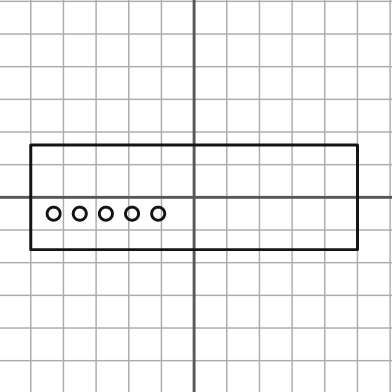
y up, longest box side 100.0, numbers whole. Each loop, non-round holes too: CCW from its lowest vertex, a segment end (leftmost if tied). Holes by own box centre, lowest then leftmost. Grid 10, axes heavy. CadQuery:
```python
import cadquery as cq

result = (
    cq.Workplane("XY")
    .moveTo(-50.0, -16.0)
    .lineTo(50.0, -16.0)
    .lineTo(50.0, 16.0)
    .lineTo(-50.0, 16.0)
    .close()
    .moveTo(-43.0, -5.0)
    .circle(2.0)
    .moveTo(-35.0, -5.0)
    .circle(2.0)
    .moveTo(-27.0, -5.0)
    .circle(2.0)
    .moveTo(-19.0, -5.0)
    .circle(2.0)
    .moveTo(-11.0, -5.0)
    .circle(2.0)
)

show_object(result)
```